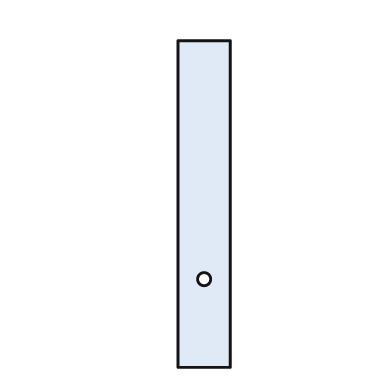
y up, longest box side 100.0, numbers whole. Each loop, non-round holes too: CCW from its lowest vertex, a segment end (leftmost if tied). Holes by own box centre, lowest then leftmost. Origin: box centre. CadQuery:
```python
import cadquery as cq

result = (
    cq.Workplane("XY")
    .moveTo(-8.0, -50.0)
    .lineTo(8.0, -50.0)
    .lineTo(8.0, 50.0)
    .lineTo(-8.0, 50.0)
    .close()
    .moveTo(0.0, -23.0)
    .circle(2.0)
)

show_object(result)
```